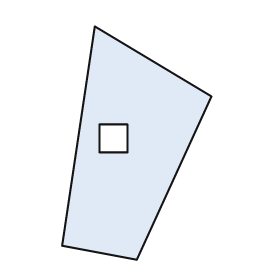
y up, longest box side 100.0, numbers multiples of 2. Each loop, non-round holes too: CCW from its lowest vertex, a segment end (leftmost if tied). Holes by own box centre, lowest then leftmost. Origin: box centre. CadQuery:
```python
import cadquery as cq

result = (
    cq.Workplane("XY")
    .moveTo(0.0, -50.0)
    .lineTo(32.0, 20.0)
    .lineTo(-18.0, 50.0)
    .lineTo(-32.0, -44.0)
    .close()
    .moveTo(-16.0, -4.0)
    .lineTo(-4.0, -4.0)
    .lineTo(-4.0, 8.0)
    .lineTo(-16.0, 8.0)
    .close()
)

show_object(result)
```